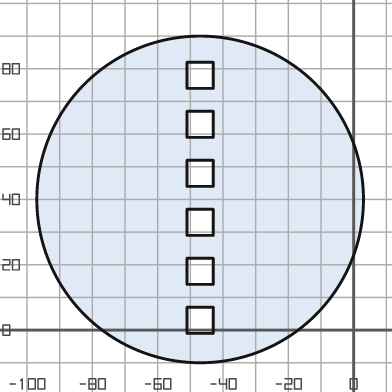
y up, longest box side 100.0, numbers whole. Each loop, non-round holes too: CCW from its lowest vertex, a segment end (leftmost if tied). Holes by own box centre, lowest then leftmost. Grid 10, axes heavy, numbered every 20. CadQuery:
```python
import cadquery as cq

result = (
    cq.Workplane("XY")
    .moveTo(-47.0, 40.0)
    .circle(50.0)
    .moveTo(-51.0, -1.0)
    .lineTo(-43.0, -1.0)
    .lineTo(-43.0, 7.0)
    .lineTo(-51.0, 7.0)
    .close()
    .moveTo(-51.0, 14.0)
    .lineTo(-43.0, 14.0)
    .lineTo(-43.0, 22.0)
    .lineTo(-51.0, 22.0)
    .close()
    .moveTo(-51.0, 29.0)
    .lineTo(-43.0, 29.0)
    .lineTo(-43.0, 37.0)
    .lineTo(-51.0, 37.0)
    .close()
    .moveTo(-51.0, 44.0)
    .lineTo(-43.0, 44.0)
    .lineTo(-43.0, 52.0)
    .lineTo(-51.0, 52.0)
    .close()
    .moveTo(-51.0, 59.0)
    .lineTo(-43.0, 59.0)
    .lineTo(-43.0, 67.0)
    .lineTo(-51.0, 67.0)
    .close()
    .moveTo(-51.0, 74.0)
    .lineTo(-43.0, 74.0)
    .lineTo(-43.0, 82.0)
    .lineTo(-51.0, 82.0)
    .close()
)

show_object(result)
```